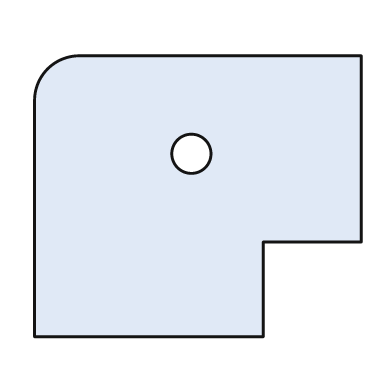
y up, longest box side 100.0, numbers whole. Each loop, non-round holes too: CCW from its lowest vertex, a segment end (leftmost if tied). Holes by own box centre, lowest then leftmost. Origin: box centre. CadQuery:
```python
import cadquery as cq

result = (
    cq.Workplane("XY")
    .moveTo(-50.0, -43.0)
    .lineTo(20.0, -43.0)
    .lineTo(20.0, -14.0)
    .lineTo(50.0, -14.0)
    .lineTo(50.0, 43.0)
    .lineTo(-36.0, 43.0)
    .threePointArc((-46.0, 39.0), (-50.0, 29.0))
    .close()
    .moveTo(-2.0, 13.0)
    .circle(6.0)
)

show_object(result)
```